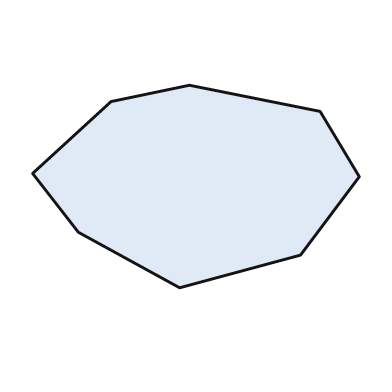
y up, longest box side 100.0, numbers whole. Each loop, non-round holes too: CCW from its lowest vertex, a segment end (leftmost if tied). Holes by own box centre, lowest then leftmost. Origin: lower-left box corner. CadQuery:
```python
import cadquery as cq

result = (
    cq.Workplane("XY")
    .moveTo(45.0, 0.0)
    .lineTo(82.0, 10.0)
    .lineTo(100.0, 34.0)
    .lineTo(88.0, 54.0)
    .lineTo(48.0, 62.0)
    .lineTo(24.0, 57.0)
    .lineTo(0.0, 35.0)
    .lineTo(14.0, 17.0)
    .close()
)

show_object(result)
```